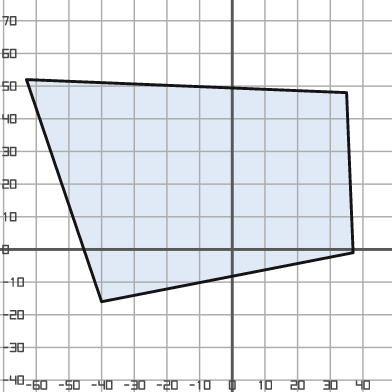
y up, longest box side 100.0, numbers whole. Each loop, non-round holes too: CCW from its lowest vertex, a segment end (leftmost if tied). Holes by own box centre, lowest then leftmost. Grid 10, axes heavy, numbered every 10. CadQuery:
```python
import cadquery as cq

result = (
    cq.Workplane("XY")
    .moveTo(-40.0, -16.0)
    .lineTo(37.0, -1.0)
    .lineTo(35.0, 48.0)
    .lineTo(-63.0, 52.0)
    .close()
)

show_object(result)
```